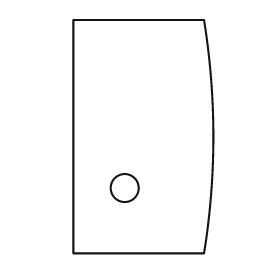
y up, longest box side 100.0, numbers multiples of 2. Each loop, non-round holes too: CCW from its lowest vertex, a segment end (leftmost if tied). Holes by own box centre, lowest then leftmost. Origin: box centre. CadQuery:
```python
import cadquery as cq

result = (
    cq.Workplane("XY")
    .moveTo(-30.0, -50.0)
    .lineTo(26.0, -50.0)
    .threePointArc((30.0, 0.0), (26.0, 50.0))
    .lineTo(-30.0, 50.0)
    .close()
    .moveTo(-8.0, -22.0)
    .circle(6.0)
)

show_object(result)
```